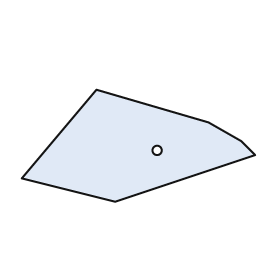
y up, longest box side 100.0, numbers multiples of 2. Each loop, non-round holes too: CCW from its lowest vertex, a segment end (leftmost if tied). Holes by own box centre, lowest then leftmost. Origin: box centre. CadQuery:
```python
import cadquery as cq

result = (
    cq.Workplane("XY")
    .moveTo(-10.0, -24.0)
    .lineTo(50.0, -4.0)
    .lineTo(44.0, 2.0)
    .lineTo(30.0, 10.0)
    .lineTo(-18.0, 24.0)
    .lineTo(-50.0, -14.0)
    .close()
    .moveTo(8.0, -2.0)
    .circle(2.0)
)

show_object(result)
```